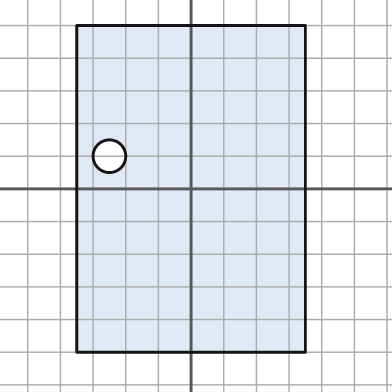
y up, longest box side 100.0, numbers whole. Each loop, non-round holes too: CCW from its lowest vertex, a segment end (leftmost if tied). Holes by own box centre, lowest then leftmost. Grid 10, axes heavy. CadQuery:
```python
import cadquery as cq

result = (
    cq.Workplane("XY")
    .moveTo(-35.0, -50.0)
    .lineTo(35.0, -50.0)
    .lineTo(35.0, 50.0)
    .lineTo(-35.0, 50.0)
    .close()
    .moveTo(-25.0, 10.0)
    .circle(5.0)
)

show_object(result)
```